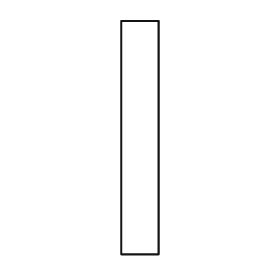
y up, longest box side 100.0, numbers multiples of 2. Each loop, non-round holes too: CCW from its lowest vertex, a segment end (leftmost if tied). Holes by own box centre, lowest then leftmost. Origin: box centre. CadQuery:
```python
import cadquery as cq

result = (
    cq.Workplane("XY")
    .moveTo(-8.0, -50.0)
    .lineTo(8.0, -50.0)
    .lineTo(8.0, 50.0)
    .lineTo(-8.0, 50.0)
    .close()
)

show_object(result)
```